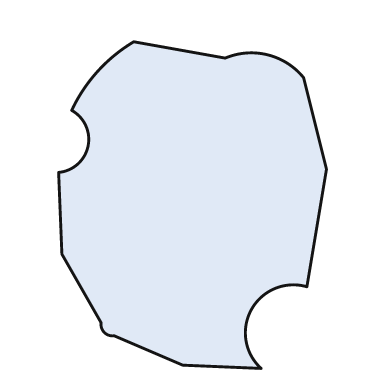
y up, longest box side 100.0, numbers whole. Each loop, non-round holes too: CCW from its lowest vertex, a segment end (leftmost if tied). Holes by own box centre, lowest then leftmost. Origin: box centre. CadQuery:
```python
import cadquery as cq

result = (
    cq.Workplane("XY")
    .moveTo(21.0, -50.0)
    .threePointArc((18.0, -32.0), (35.0, -25.0))
    .lineTo(41.0, 11.0)
    .lineTo(34.0, 39.0)
    .threePointArc((23.0, 46.0), (10.0, 45.0))
    .lineTo(-18.0, 50.0)
    .threePointArc((-29.0, 41.0), (-37.0, 29.0))
    .threePointArc((-32.0, 18.0), (-41.0, 10.0))
    .lineTo(-40.0, -15.0)
    .lineTo(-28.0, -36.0)
    .threePointArc((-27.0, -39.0), (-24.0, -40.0))
    .lineTo(-3.0, -49.0)
    .close()
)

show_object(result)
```